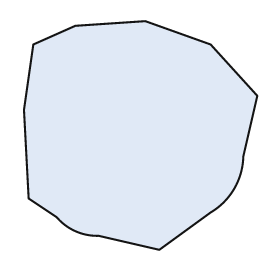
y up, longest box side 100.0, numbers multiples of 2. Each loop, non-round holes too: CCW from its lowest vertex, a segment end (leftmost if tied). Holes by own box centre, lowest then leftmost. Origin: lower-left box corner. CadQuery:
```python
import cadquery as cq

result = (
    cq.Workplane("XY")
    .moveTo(58.0, 0.0)
    .lineTo(80.0, 16.0)
    .threePointArc((90.0, 26.0), (94.0, 40.0))
    .lineTo(100.0, 66.0)
    .lineTo(80.0, 88.0)
    .lineTo(52.0, 98.0)
    .lineTo(22.0, 96.0)
    .lineTo(4.0, 88.0)
    .lineTo(0.0, 60.0)
    .lineTo(2.0, 22.0)
    .lineTo(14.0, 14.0)
    .threePointArc((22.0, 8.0), (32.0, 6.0))
    .close()
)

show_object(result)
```